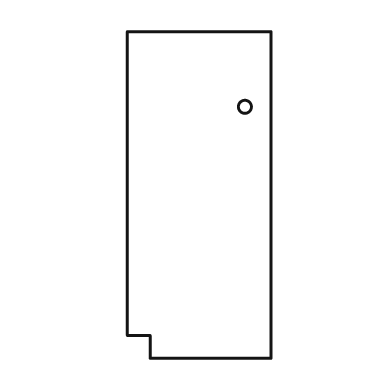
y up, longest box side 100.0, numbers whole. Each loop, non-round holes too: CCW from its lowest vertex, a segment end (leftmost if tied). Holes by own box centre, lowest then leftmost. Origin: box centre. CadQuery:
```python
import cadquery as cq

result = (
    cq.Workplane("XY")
    .moveTo(-15.0, -50.0)
    .lineTo(22.0, -50.0)
    .lineTo(22.0, 50.0)
    .lineTo(-22.0, 50.0)
    .lineTo(-22.0, -43.0)
    .lineTo(-15.0, -43.0)
    .close()
    .moveTo(14.0, 27.0)
    .circle(2.0)
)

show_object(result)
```